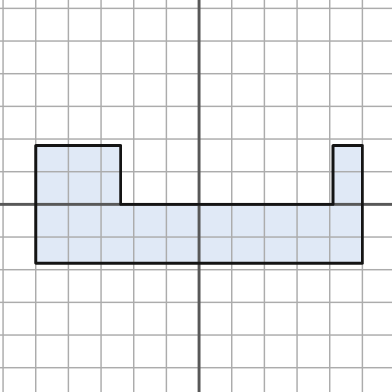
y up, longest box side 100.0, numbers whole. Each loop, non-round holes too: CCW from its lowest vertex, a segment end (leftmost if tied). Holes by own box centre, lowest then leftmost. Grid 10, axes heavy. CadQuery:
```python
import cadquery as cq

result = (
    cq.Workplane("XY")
    .moveTo(-50.0, -18.0)
    .lineTo(50.0, -18.0)
    .lineTo(50.0, 18.0)
    .lineTo(41.0, 18.0)
    .lineTo(41.0, 0.0)
    .lineTo(-24.0, 0.0)
    .lineTo(-24.0, 18.0)
    .lineTo(-50.0, 18.0)
    .close()
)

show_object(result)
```